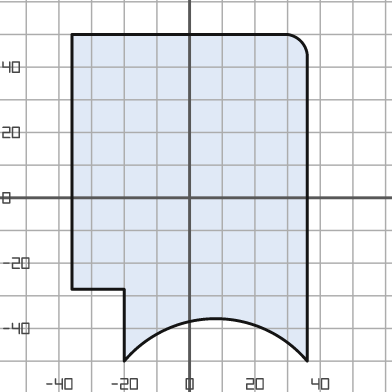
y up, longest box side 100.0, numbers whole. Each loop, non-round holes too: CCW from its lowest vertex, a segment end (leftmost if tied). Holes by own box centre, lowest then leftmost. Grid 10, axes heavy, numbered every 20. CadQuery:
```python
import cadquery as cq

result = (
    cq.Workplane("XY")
    .moveTo(-20.0, -50.0)
    .threePointArc((8.0, -37.0), (36.0, -50.0))
    .lineTo(36.0, 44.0)
    .threePointArc((34.0, 48.0), (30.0, 50.0))
    .lineTo(-36.0, 50.0)
    .lineTo(-36.0, -28.0)
    .lineTo(-20.0, -28.0)
    .close()
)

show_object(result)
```